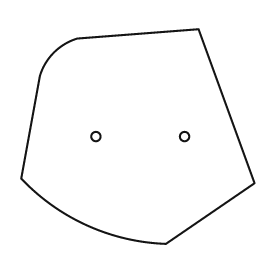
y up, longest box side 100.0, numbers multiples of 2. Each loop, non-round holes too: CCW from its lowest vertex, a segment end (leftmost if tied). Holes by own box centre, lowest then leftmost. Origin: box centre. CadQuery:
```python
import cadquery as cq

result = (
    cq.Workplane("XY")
    .moveTo(12.0, -46.0)
    .lineTo(50.0, -20.0)
    .lineTo(26.0, 46.0)
    .lineTo(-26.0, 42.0)
    .threePointArc((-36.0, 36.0), (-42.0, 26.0))
    .lineTo(-50.0, -18.0)
    .threePointArc((-22.0, -38.0), (12.0, -46.0))
    .close()
    .moveTo(-18.0, 0.0)
    .circle(2.0)
    .moveTo(20.0, 0.0)
    .circle(2.0)
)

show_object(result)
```